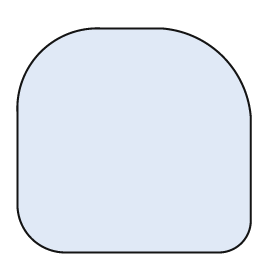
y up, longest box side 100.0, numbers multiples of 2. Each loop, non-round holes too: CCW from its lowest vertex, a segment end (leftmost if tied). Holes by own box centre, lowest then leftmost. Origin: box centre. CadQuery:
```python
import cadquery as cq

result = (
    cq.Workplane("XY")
    .moveTo(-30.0, -48.0)
    .lineTo(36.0, -48.0)
    .threePointArc((46.0, -44.0), (50.0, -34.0))
    .lineTo(50.0, 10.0)
    .threePointArc((38.0, 36.0), (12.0, 48.0))
    .lineTo(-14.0, 48.0)
    .threePointArc((-40.0, 38.0), (-50.0, 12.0))
    .lineTo(-50.0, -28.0)
    .threePointArc((-44.0, -42.0), (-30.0, -48.0))
    .close()
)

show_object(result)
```